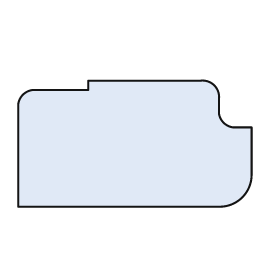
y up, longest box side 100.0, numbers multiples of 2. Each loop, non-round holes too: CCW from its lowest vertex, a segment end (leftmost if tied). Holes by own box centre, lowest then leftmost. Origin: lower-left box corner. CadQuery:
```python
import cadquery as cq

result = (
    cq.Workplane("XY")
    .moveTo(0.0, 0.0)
    .lineTo(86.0, 0.0)
    .threePointArc((96.0, 4.0), (100.0, 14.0))
    .lineTo(100.0, 34.0)
    .lineTo(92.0, 34.0)
    .threePointArc((88.0, 36.0), (86.0, 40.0))
    .lineTo(86.0, 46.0)
    .threePointArc((84.0, 52.0), (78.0, 54.0))
    .lineTo(30.0, 54.0)
    .lineTo(30.0, 50.0)
    .lineTo(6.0, 50.0)
    .threePointArc((2.0, 48.0), (0.0, 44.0))
    .close()
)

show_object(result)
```